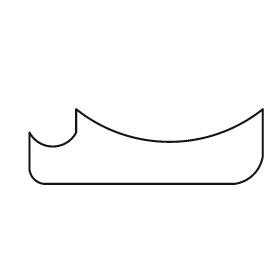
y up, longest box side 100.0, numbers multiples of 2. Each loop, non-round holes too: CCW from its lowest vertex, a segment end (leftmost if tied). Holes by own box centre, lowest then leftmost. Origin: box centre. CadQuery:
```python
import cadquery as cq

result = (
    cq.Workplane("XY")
    .moveTo(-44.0, -16.0)
    .lineTo(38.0, -16.0)
    .threePointArc((46.0, -12.0), (50.0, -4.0))
    .lineTo(50.0, 16.0)
    .threePointArc((10.0, 2.0), (-30.0, 16.0))
    .lineTo(-30.0, 6.0)
    .threePointArc((-40.0, 0.0), (-50.0, 6.0))
    .lineTo(-50.0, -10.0)
    .threePointArc((-48.0, -14.0), (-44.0, -16.0))
    .close()
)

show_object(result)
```